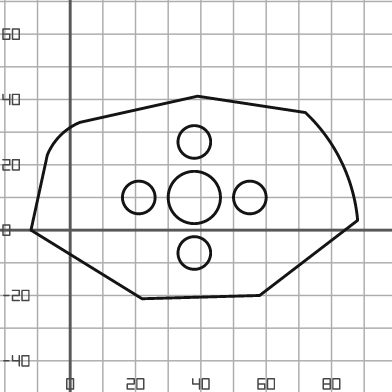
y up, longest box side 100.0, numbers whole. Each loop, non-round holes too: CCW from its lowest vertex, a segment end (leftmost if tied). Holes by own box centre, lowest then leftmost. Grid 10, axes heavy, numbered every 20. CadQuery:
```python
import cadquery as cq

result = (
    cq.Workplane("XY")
    .moveTo(22.0, -21.0)
    .lineTo(58.0, -20.0)
    .lineTo(88.0, 3.0)
    .threePointArc((83.0, 21.0), (72.0, 36.0))
    .lineTo(39.0, 41.0)
    .lineTo(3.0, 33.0)
    .threePointArc((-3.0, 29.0), (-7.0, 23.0))
    .lineTo(-12.0, 0.0)
    .close()
    .moveTo(38.0, -7.0)
    .circle(5.0)
    .moveTo(21.0, 10.0)
    .circle(5.0)
    .moveTo(38.0, 10.0)
    .circle(8.0)
    .moveTo(55.0, 10.0)
    .circle(5.0)
    .moveTo(38.0, 27.0)
    .circle(5.0)
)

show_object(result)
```